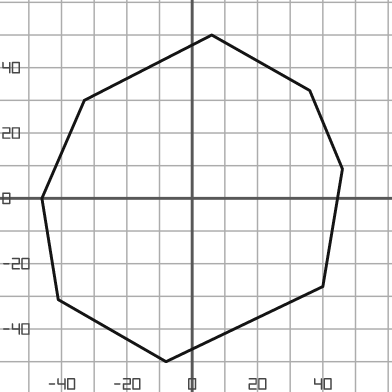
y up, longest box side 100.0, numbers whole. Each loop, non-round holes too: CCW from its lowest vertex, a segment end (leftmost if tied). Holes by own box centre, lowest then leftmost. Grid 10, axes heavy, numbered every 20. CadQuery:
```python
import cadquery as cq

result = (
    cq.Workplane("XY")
    .moveTo(-8.0, -50.0)
    .lineTo(40.0, -27.0)
    .lineTo(46.0, 9.0)
    .lineTo(36.0, 33.0)
    .lineTo(6.0, 50.0)
    .lineTo(-33.0, 30.0)
    .lineTo(-46.0, 0.0)
    .lineTo(-41.0, -31.0)
    .close()
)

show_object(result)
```